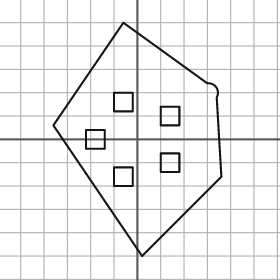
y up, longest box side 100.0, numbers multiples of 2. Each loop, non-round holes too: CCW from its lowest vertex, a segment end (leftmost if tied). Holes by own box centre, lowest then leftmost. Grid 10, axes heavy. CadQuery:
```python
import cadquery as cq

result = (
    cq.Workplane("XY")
    .moveTo(2.0, -50.0)
    .lineTo(36.0, -16.0)
    .lineTo(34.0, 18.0)
    .threePointArc((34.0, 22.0), (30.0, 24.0))
    .lineTo(-6.0, 50.0)
    .lineTo(-36.0, 6.0)
    .close()
    .moveTo(-10.0, -20.0)
    .lineTo(-2.0, -20.0)
    .lineTo(-2.0, -12.0)
    .lineTo(-10.0, -12.0)
    .close()
    .moveTo(10.0, -14.0)
    .lineTo(18.0, -14.0)
    .lineTo(18.0, -6.0)
    .lineTo(10.0, -6.0)
    .close()
    .moveTo(-22.0, -4.0)
    .lineTo(-14.0, -4.0)
    .lineTo(-14.0, 4.0)
    .lineTo(-22.0, 4.0)
    .close()
    .moveTo(10.0, 6.0)
    .lineTo(18.0, 6.0)
    .lineTo(18.0, 14.0)
    .lineTo(10.0, 14.0)
    .close()
    .moveTo(-10.0, 12.0)
    .lineTo(-2.0, 12.0)
    .lineTo(-2.0, 20.0)
    .lineTo(-10.0, 20.0)
    .close()
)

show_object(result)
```